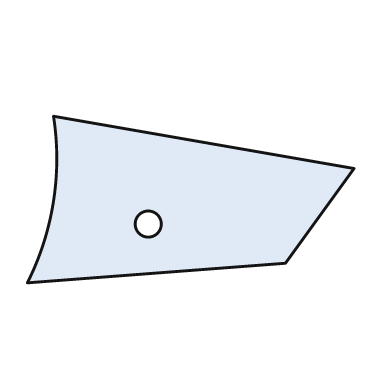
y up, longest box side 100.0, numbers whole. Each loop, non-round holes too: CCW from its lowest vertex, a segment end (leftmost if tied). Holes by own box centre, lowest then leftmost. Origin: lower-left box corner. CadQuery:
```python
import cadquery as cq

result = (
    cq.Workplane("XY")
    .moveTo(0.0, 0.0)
    .lineTo(79.0, 6.0)
    .lineTo(100.0, 35.0)
    .lineTo(8.0, 51.0)
    .threePointArc((8.0, 25.0), (0.0, 0.0))
    .close()
    .moveTo(37.0, 18.0)
    .circle(4.0)
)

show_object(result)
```